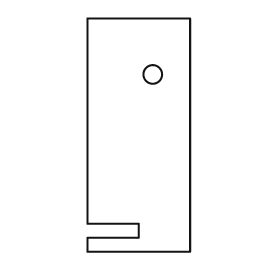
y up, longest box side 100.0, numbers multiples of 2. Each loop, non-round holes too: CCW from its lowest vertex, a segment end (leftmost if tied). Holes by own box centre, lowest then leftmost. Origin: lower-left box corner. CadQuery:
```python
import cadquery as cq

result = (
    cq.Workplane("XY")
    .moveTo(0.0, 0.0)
    .lineTo(44.0, 0.0)
    .lineTo(44.0, 100.0)
    .lineTo(0.0, 100.0)
    .lineTo(0.0, 12.0)
    .lineTo(22.0, 12.0)
    .lineTo(22.0, 6.0)
    .lineTo(0.0, 6.0)
    .close()
    .moveTo(28.0, 76.0)
    .circle(4.0)
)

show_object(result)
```